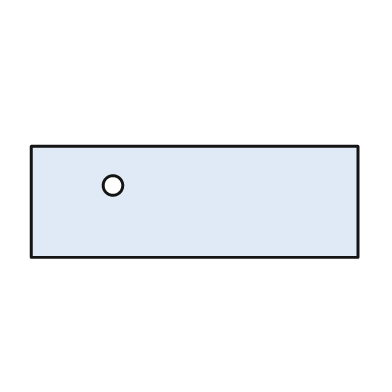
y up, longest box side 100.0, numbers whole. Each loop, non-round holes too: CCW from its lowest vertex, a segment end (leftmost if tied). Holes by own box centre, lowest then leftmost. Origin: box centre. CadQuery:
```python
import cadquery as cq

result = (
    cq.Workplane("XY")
    .moveTo(-50.0, -17.0)
    .lineTo(50.0, -17.0)
    .lineTo(50.0, 17.0)
    .lineTo(-50.0, 17.0)
    .close()
    .moveTo(-25.0, 5.0)
    .circle(3.0)
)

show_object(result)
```